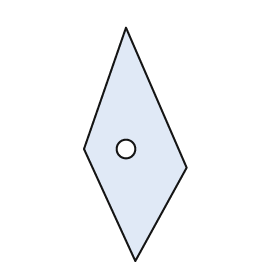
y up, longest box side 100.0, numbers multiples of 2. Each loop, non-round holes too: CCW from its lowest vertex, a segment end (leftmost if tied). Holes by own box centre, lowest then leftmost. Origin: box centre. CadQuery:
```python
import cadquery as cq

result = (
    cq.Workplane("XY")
    .moveTo(0.0, -50.0)
    .lineTo(22.0, -10.0)
    .lineTo(-4.0, 50.0)
    .lineTo(-22.0, -2.0)
    .close()
    .moveTo(-4.0, -2.0)
    .circle(4.0)
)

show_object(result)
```